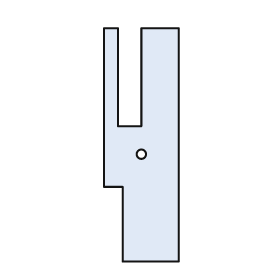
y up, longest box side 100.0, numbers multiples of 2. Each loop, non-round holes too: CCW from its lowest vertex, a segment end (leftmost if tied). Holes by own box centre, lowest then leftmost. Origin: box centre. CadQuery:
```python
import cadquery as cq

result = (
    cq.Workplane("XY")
    .moveTo(-8.0, -50.0)
    .lineTo(16.0, -50.0)
    .lineTo(16.0, 50.0)
    .lineTo(0.0, 50.0)
    .lineTo(0.0, 8.0)
    .lineTo(-10.0, 8.0)
    .lineTo(-10.0, 50.0)
    .lineTo(-16.0, 50.0)
    .lineTo(-16.0, -18.0)
    .lineTo(-8.0, -18.0)
    .close()
    .moveTo(0.0, -4.0)
    .circle(2.0)
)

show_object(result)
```